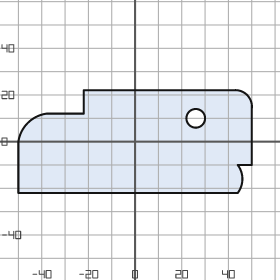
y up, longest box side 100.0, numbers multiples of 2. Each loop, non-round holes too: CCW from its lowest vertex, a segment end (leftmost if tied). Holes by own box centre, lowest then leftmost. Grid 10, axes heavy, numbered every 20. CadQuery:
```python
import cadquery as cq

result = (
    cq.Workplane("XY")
    .moveTo(-50.0, -22.0)
    .lineTo(44.0, -22.0)
    .threePointArc((46.0, -16.0), (44.0, -10.0))
    .lineTo(50.0, -10.0)
    .lineTo(50.0, 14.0)
    .threePointArc((48.0, 20.0), (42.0, 22.0))
    .lineTo(-22.0, 22.0)
    .lineTo(-22.0, 12.0)
    .lineTo(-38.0, 12.0)
    .threePointArc((-46.0, 8.0), (-50.0, 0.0))
    .close()
    .moveTo(26.0, 10.0)
    .circle(4.0)
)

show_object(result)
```